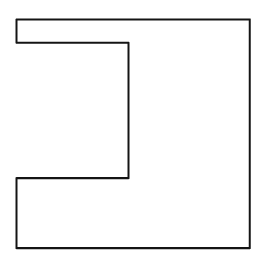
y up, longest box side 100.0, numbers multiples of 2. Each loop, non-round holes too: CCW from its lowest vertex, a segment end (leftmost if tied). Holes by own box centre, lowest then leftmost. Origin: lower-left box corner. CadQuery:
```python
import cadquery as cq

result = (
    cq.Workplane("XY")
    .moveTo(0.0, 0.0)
    .lineTo(100.0, 0.0)
    .lineTo(100.0, 98.0)
    .lineTo(0.0, 98.0)
    .lineTo(0.0, 88.0)
    .lineTo(48.0, 88.0)
    .lineTo(48.0, 30.0)
    .lineTo(0.0, 30.0)
    .close()
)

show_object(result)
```